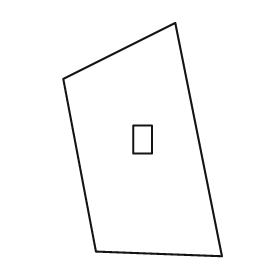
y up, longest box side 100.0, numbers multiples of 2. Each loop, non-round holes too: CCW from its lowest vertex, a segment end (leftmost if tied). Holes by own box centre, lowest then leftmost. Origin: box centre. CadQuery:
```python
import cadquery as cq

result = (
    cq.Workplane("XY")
    .moveTo(34.0, -50.0)
    .lineTo(14.0, 50.0)
    .lineTo(-34.0, 26.0)
    .lineTo(-20.0, -48.0)
    .close()
    .moveTo(-4.0, -6.0)
    .lineTo(4.0, -6.0)
    .lineTo(4.0, 6.0)
    .lineTo(-4.0, 6.0)
    .close()
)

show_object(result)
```